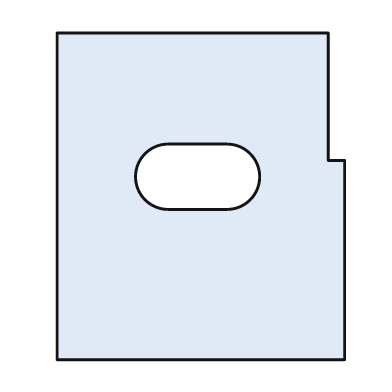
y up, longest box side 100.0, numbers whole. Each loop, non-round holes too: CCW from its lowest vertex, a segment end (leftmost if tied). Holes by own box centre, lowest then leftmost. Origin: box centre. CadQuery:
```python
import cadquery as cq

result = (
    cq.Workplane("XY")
    .moveTo(-44.0, -50.0)
    .lineTo(44.0, -50.0)
    .lineTo(44.0, 11.0)
    .lineTo(39.0, 11.0)
    .lineTo(39.0, 50.0)
    .lineTo(-44.0, 50.0)
    .close()
    .moveTo(-10.0, -4.0)
    .lineTo(8.0, -4.0)
    .threePointArc((18.0, 6.0), (8.0, 16.0))
    .lineTo(-10.0, 16.0)
    .threePointArc((-20.0, 6.0), (-10.0, -4.0))
    .close()
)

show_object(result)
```